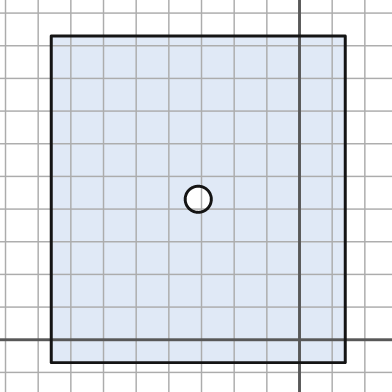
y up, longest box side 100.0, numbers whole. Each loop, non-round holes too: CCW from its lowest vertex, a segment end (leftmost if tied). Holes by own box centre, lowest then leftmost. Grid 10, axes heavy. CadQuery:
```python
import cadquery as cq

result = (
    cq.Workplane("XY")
    .moveTo(-76.0, -7.0)
    .lineTo(14.0, -7.0)
    .lineTo(14.0, 93.0)
    .lineTo(-76.0, 93.0)
    .close()
    .moveTo(-31.0, 43.0)
    .circle(4.0)
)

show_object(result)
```